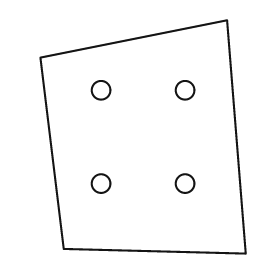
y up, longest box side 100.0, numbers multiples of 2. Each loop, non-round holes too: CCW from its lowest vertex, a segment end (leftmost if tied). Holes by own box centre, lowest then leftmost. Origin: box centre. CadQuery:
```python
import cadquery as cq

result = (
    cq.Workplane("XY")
    .moveTo(44.0, -50.0)
    .lineTo(36.0, 50.0)
    .lineTo(-44.0, 34.0)
    .lineTo(-34.0, -48.0)
    .close()
    .moveTo(-18.0, -20.0)
    .circle(4.0)
    .moveTo(18.0, -20.0)
    .circle(4.0)
    .moveTo(-18.0, 20.0)
    .circle(4.0)
    .moveTo(18.0, 20.0)
    .circle(4.0)
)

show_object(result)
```